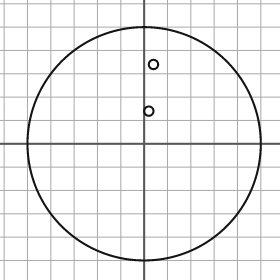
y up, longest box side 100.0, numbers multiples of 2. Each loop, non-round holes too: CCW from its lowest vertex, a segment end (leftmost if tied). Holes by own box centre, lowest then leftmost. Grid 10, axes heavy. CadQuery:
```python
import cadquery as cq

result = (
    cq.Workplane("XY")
    .moveTo(0.0, 0.0)
    .circle(50.0)
    .moveTo(2.0, 14.0)
    .circle(2.0)
    .moveTo(4.0, 34.0)
    .circle(2.0)
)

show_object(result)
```